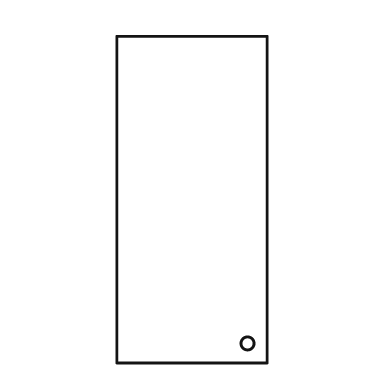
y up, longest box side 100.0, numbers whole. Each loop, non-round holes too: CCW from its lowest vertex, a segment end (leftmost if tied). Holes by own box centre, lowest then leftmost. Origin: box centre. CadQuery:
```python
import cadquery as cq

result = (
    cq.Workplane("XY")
    .moveTo(-23.0, -50.0)
    .lineTo(23.0, -50.0)
    .lineTo(23.0, 50.0)
    .lineTo(-23.0, 50.0)
    .close()
    .moveTo(17.0, -44.0)
    .circle(2.0)
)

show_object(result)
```